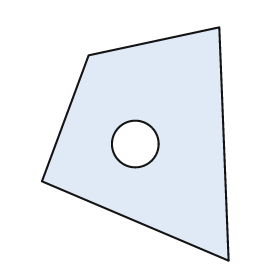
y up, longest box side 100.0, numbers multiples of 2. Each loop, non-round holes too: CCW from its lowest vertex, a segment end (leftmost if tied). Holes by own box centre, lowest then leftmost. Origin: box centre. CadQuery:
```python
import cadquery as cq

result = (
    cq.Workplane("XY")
    .moveTo(40.0, -50.0)
    .lineTo(36.0, 50.0)
    .lineTo(-20.0, 38.0)
    .lineTo(-40.0, -16.0)
    .close()
    .moveTo(0.0, 0.0)
    .circle(10.0)
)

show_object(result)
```